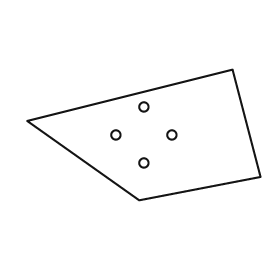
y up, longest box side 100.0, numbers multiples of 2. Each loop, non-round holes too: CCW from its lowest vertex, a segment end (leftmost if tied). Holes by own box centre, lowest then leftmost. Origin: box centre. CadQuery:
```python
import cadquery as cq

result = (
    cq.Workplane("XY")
    .moveTo(-2.0, -28.0)
    .lineTo(50.0, -18.0)
    .lineTo(38.0, 28.0)
    .lineTo(-50.0, 6.0)
    .close()
    .moveTo(0.0, -12.0)
    .circle(2.0)
    .moveTo(-12.0, 0.0)
    .circle(2.0)
    .moveTo(12.0, 0.0)
    .circle(2.0)
    .moveTo(0.0, 12.0)
    .circle(2.0)
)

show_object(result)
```